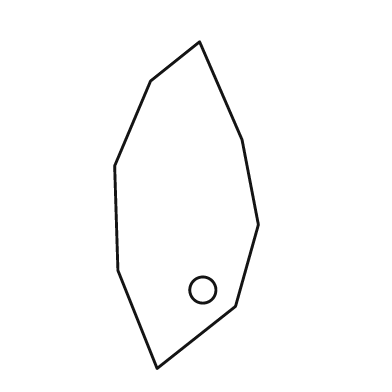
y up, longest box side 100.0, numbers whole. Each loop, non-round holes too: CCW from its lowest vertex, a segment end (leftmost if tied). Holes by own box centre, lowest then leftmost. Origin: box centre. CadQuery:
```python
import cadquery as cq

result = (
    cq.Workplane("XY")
    .moveTo(-9.0, -50.0)
    .lineTo(15.0, -31.0)
    .lineTo(22.0, -6.0)
    .lineTo(17.0, 20.0)
    .lineTo(4.0, 50.0)
    .lineTo(-11.0, 38.0)
    .lineTo(-22.0, 12.0)
    .lineTo(-21.0, -20.0)
    .close()
    .moveTo(5.0, -26.0)
    .circle(4.0)
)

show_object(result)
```